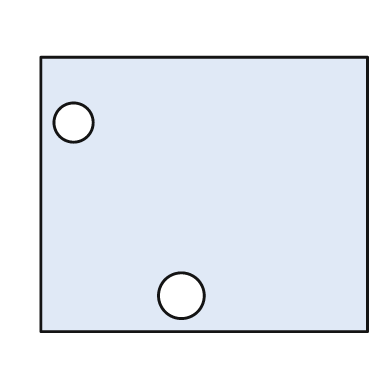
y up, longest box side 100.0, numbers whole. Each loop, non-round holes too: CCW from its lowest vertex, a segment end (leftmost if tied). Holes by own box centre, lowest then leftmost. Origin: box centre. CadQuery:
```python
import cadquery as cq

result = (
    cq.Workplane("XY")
    .moveTo(-50.0, -42.0)
    .lineTo(50.0, -42.0)
    .lineTo(50.0, 42.0)
    .lineTo(-50.0, 42.0)
    .close()
    .moveTo(-7.0, -31.0)
    .circle(7.0)
    .moveTo(-40.0, 22.0)
    .circle(6.0)
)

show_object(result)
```